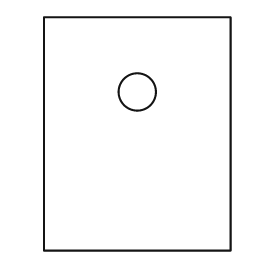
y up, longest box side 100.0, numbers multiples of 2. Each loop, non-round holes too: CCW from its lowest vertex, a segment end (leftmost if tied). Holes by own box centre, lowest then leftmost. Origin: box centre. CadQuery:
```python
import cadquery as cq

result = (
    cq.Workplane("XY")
    .moveTo(-40.0, -50.0)
    .lineTo(40.0, -50.0)
    .lineTo(40.0, 50.0)
    .lineTo(-40.0, 50.0)
    .close()
    .moveTo(0.0, 18.0)
    .circle(8.0)
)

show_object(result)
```